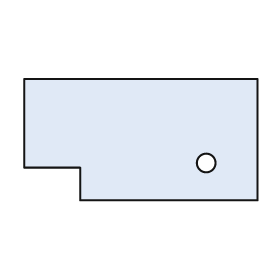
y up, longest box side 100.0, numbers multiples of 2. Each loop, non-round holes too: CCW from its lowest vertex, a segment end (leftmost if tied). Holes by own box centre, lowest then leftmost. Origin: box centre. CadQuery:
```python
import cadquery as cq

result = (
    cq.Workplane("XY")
    .moveTo(-26.0, -26.0)
    .lineTo(50.0, -26.0)
    .lineTo(50.0, 26.0)
    .lineTo(-50.0, 26.0)
    .lineTo(-50.0, -12.0)
    .lineTo(-26.0, -12.0)
    .close()
    .moveTo(28.0, -10.0)
    .circle(4.0)
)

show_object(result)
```